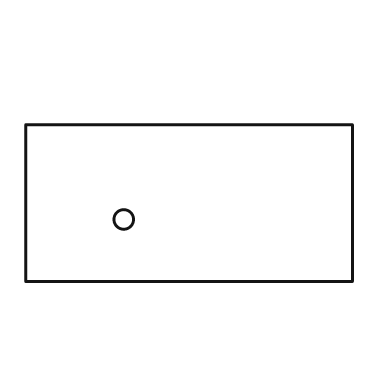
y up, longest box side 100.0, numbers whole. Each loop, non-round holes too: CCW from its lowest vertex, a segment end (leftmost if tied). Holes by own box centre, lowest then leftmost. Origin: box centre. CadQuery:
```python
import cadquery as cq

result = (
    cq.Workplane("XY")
    .moveTo(-50.0, -24.0)
    .lineTo(50.0, -24.0)
    .lineTo(50.0, 24.0)
    .lineTo(-50.0, 24.0)
    .close()
    .moveTo(-20.0, -5.0)
    .circle(3.0)
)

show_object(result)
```